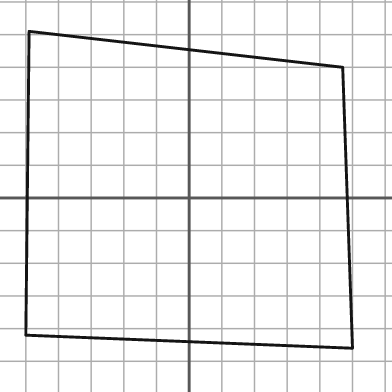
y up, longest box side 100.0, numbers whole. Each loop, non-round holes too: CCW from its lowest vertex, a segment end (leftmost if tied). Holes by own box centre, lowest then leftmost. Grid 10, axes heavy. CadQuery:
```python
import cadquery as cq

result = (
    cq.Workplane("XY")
    .moveTo(50.0, -46.0)
    .lineTo(47.0, 40.0)
    .lineTo(-49.0, 51.0)
    .lineTo(-50.0, -42.0)
    .close()
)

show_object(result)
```